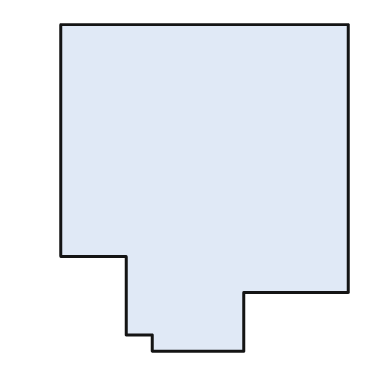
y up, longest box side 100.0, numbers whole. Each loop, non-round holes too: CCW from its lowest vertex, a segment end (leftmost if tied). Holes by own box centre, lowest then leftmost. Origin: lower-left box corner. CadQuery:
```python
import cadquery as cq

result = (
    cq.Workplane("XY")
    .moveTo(28.0, 0.0)
    .lineTo(56.0, 0.0)
    .lineTo(56.0, 18.0)
    .lineTo(88.0, 18.0)
    .lineTo(88.0, 100.0)
    .lineTo(0.0, 100.0)
    .lineTo(0.0, 29.0)
    .lineTo(20.0, 29.0)
    .lineTo(20.0, 5.0)
    .lineTo(28.0, 5.0)
    .close()
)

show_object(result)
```